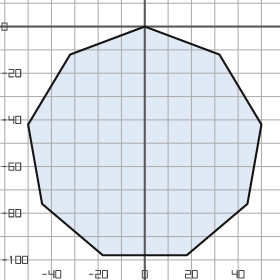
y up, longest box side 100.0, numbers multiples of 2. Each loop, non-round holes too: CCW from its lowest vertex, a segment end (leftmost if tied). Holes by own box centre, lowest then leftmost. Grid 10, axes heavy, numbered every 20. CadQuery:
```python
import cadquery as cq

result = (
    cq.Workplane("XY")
    .moveTo(-18.0, -98.0)
    .lineTo(18.0, -98.0)
    .lineTo(44.0, -76.0)
    .lineTo(50.0, -42.0)
    .lineTo(32.0, -12.0)
    .lineTo(0.0, 0.0)
    .lineTo(-32.0, -12.0)
    .lineTo(-50.0, -42.0)
    .lineTo(-44.0, -76.0)
    .close()
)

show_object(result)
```